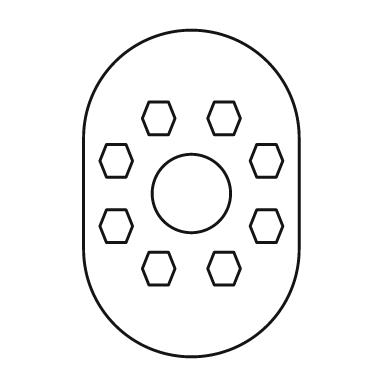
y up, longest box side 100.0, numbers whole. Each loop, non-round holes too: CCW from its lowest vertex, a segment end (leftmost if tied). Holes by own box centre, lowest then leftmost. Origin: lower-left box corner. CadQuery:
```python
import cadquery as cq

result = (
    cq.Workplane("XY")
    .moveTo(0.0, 33.0)
    .threePointArc((33.0, 0.0), (66.0, 33.0))
    .lineTo(66.0, 67.0)
    .threePointArc((33.0, 100.0), (0.0, 67.0))
    .close()
    .moveTo(20.0, 22.0)
    .lineTo(26.0, 22.0)
    .lineTo(28.0, 27.0)
    .lineTo(26.0, 32.0)
    .lineTo(20.0, 32.0)
    .lineTo(18.0, 27.0)
    .close()
    .moveTo(40.0, 22.0)
    .lineTo(46.0, 22.0)
    .lineTo(48.0, 27.0)
    .lineTo(46.0, 32.0)
    .lineTo(40.0, 32.0)
    .lineTo(38.0, 27.0)
    .close()
    .moveTo(7.0, 35.0)
    .lineTo(13.0, 35.0)
    .lineTo(15.0, 40.0)
    .lineTo(13.0, 45.0)
    .lineTo(7.0, 45.0)
    .lineTo(5.0, 40.0)
    .close()
    .moveTo(53.0, 35.0)
    .lineTo(59.0, 35.0)
    .lineTo(61.0, 40.0)
    .lineTo(59.0, 45.0)
    .lineTo(53.0, 45.0)
    .lineTo(51.0, 40.0)
    .close()
    .moveTo(33.0, 50.0)
    .circle(12.0)
    .moveTo(7.0, 55.0)
    .lineTo(13.0, 55.0)
    .lineTo(15.0, 60.0)
    .lineTo(13.0, 65.0)
    .lineTo(7.0, 65.0)
    .lineTo(5.0, 60.0)
    .close()
    .moveTo(53.0, 55.0)
    .lineTo(59.0, 55.0)
    .lineTo(61.0, 60.0)
    .lineTo(59.0, 65.0)
    .lineTo(53.0, 65.0)
    .lineTo(51.0, 60.0)
    .close()
    .moveTo(20.0, 68.0)
    .lineTo(26.0, 68.0)
    .lineTo(28.0, 73.0)
    .lineTo(26.0, 78.0)
    .lineTo(20.0, 78.0)
    .lineTo(18.0, 73.0)
    .close()
    .moveTo(40.0, 68.0)
    .lineTo(46.0, 68.0)
    .lineTo(48.0, 73.0)
    .lineTo(46.0, 78.0)
    .lineTo(40.0, 78.0)
    .lineTo(38.0, 73.0)
    .close()
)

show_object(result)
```